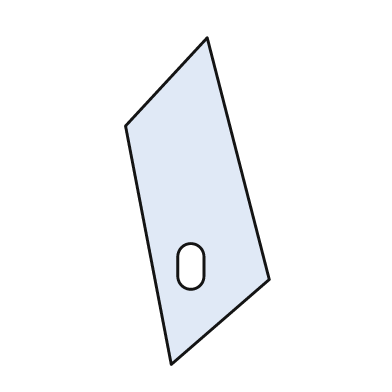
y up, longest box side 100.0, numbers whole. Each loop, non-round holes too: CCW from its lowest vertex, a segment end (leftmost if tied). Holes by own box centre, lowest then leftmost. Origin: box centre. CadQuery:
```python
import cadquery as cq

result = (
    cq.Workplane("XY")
    .moveTo(-8.0, -50.0)
    .lineTo(22.0, -24.0)
    .lineTo(3.0, 50.0)
    .lineTo(-22.0, 23.0)
    .close()
    .moveTo(-6.0, -23.0)
    .threePointArc((-2.0, -27.0), (2.0, -23.0))
    .lineTo(2.0, -17.0)
    .threePointArc((-2.0, -13.0), (-6.0, -17.0))
    .close()
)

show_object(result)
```